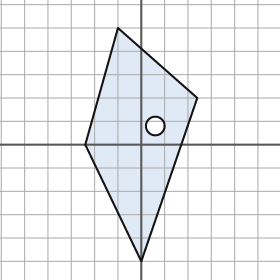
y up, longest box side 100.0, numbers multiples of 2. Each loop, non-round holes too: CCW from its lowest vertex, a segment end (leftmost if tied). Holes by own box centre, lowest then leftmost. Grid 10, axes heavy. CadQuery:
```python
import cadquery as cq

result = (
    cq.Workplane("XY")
    .moveTo(0.0, -50.0)
    .lineTo(24.0, 20.0)
    .lineTo(-10.0, 50.0)
    .lineTo(-24.0, 0.0)
    .close()
    .moveTo(6.0, 8.0)
    .circle(4.0)
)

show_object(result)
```